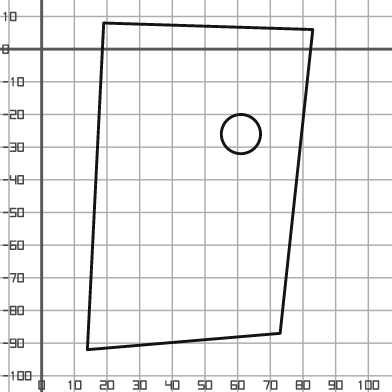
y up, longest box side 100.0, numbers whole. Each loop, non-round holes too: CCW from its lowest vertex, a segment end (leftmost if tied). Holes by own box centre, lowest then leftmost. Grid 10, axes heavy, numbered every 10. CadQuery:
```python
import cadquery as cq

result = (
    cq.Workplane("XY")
    .moveTo(14.0, -92.0)
    .lineTo(73.0, -87.0)
    .lineTo(83.0, 6.0)
    .lineTo(19.0, 8.0)
    .close()
    .moveTo(61.0, -26.0)
    .circle(6.0)
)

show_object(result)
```